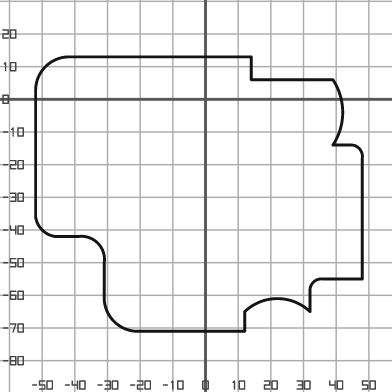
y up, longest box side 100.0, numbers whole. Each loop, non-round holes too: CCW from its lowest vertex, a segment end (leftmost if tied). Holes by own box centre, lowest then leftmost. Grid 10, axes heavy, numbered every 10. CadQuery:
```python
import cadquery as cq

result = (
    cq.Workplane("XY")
    .moveTo(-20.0, -71.0)
    .lineTo(12.0, -71.0)
    .lineTo(12.0, -65.0)
    .threePointArc((22.0, -61.0), (32.0, -65.0))
    .lineTo(32.0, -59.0)
    .threePointArc((33.0, -56.0), (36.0, -55.0))
    .lineTo(48.0, -55.0)
    .lineTo(48.0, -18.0)
    .threePointArc((47.0, -15.0), (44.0, -14.0))
    .lineTo(39.0, -14.0)
    .threePointArc((42.0, -4.0), (39.0, 6.0))
    .lineTo(14.0, 6.0)
    .lineTo(14.0, 13.0)
    .lineTo(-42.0, 13.0)
    .threePointArc((-49.0, 10.0), (-52.0, 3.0))
    .lineTo(-52.0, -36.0)
    .threePointArc((-50.0, -40.0), (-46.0, -42.0))
    .lineTo(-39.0, -42.0)
    .threePointArc((-33.0, -44.0), (-31.0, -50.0))
    .lineTo(-31.0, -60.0)
    .threePointArc((-28.0, -68.0), (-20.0, -71.0))
    .close()
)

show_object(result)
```